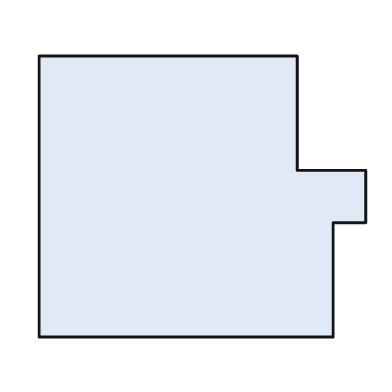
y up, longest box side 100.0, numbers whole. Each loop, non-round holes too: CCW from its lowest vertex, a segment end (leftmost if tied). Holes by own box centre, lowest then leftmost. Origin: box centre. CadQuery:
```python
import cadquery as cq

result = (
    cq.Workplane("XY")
    .moveTo(-50.0, -43.0)
    .lineTo(40.0, -43.0)
    .lineTo(40.0, -8.0)
    .lineTo(50.0, -8.0)
    .lineTo(50.0, 8.0)
    .lineTo(29.0, 8.0)
    .lineTo(29.0, 43.0)
    .lineTo(-50.0, 43.0)
    .close()
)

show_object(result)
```